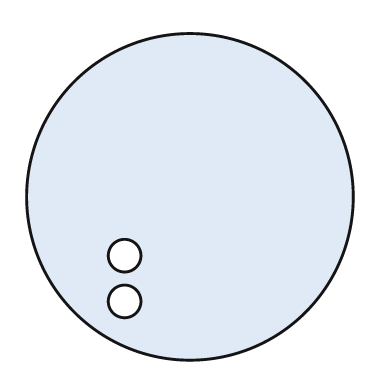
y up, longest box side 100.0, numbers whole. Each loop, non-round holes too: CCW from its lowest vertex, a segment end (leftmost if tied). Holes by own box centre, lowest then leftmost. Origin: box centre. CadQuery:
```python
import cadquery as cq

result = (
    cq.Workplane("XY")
    .moveTo(0.0, 0.0)
    .circle(50.0)
    .moveTo(-20.0, -32.0)
    .circle(5.0)
    .moveTo(-20.0, -18.0)
    .circle(5.0)
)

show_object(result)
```